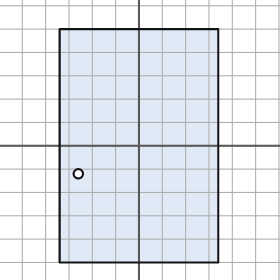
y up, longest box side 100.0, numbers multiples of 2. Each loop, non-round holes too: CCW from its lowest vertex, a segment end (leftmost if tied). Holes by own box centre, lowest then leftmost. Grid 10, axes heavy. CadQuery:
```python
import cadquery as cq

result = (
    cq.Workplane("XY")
    .moveTo(-34.0, -50.0)
    .lineTo(34.0, -50.0)
    .lineTo(34.0, 50.0)
    .lineTo(-34.0, 50.0)
    .close()
    .moveTo(-26.0, -12.0)
    .circle(2.0)
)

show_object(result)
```